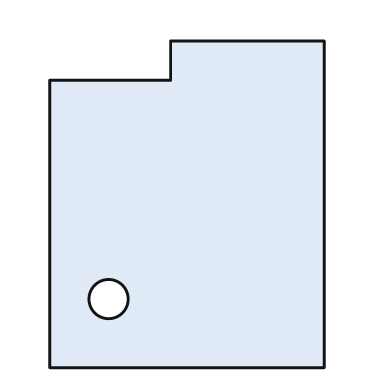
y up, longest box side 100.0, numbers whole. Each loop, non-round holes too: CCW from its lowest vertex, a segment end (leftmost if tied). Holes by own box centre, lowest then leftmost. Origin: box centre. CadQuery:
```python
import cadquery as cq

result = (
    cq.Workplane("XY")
    .moveTo(-42.0, -50.0)
    .lineTo(42.0, -50.0)
    .lineTo(42.0, 50.0)
    .lineTo(-5.0, 50.0)
    .lineTo(-5.0, 38.0)
    .lineTo(-42.0, 38.0)
    .close()
    .moveTo(-24.0, -29.0)
    .circle(6.0)
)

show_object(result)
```